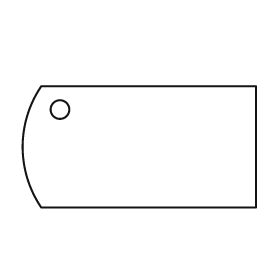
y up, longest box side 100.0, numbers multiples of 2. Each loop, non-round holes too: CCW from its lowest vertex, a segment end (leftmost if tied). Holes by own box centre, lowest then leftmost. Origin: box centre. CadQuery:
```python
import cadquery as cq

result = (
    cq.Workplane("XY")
    .moveTo(-42.0, -26.0)
    .lineTo(50.0, -26.0)
    .lineTo(50.0, 26.0)
    .lineTo(-42.0, 26.0)
    .threePointArc((-50.0, 0.0), (-42.0, -26.0))
    .close()
    .moveTo(-34.0, 16.0)
    .circle(4.0)
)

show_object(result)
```